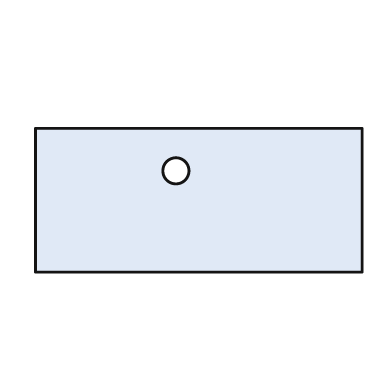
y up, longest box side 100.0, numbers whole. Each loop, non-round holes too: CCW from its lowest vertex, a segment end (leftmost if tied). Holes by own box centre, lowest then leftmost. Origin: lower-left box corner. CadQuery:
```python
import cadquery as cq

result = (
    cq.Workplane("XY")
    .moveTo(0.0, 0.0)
    .lineTo(100.0, 0.0)
    .lineTo(100.0, 44.0)
    .lineTo(0.0, 44.0)
    .close()
    .moveTo(43.0, 31.0)
    .circle(4.0)
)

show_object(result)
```